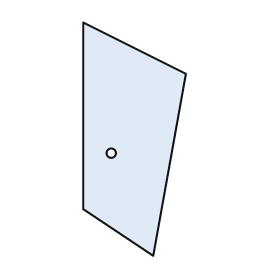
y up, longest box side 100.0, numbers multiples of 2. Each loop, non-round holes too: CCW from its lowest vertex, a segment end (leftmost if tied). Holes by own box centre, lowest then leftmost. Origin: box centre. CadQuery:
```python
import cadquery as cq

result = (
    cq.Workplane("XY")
    .moveTo(8.0, -50.0)
    .lineTo(22.0, 28.0)
    .lineTo(-22.0, 50.0)
    .lineTo(-22.0, -30.0)
    .close()
    .moveTo(-10.0, -6.0)
    .circle(2.0)
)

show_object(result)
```